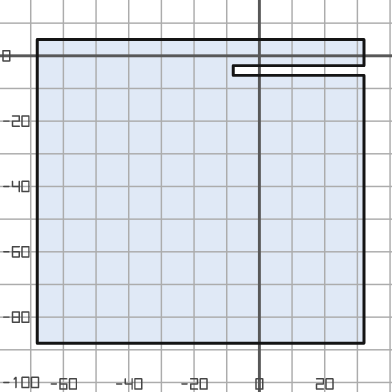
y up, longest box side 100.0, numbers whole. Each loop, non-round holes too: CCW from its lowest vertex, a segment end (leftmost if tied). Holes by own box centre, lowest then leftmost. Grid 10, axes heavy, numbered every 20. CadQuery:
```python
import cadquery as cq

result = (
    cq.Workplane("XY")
    .moveTo(-68.0, -88.0)
    .lineTo(32.0, -88.0)
    .lineTo(32.0, -6.0)
    .lineTo(-8.0, -6.0)
    .lineTo(-8.0, -3.0)
    .lineTo(32.0, -3.0)
    .lineTo(32.0, 5.0)
    .lineTo(-68.0, 5.0)
    .close()
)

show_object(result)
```